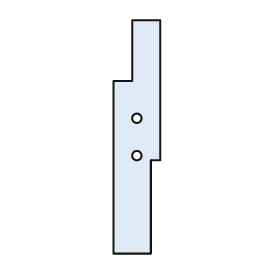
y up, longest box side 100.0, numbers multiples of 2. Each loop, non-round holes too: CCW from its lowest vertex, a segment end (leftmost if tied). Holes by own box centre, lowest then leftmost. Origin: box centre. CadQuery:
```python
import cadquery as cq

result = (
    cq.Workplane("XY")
    .moveTo(-10.0, -50.0)
    .lineTo(6.0, -50.0)
    .lineTo(6.0, -10.0)
    .lineTo(10.0, -10.0)
    .lineTo(10.0, 50.0)
    .lineTo(-2.0, 50.0)
    .lineTo(-2.0, 24.0)
    .lineTo(-10.0, 24.0)
    .close()
    .moveTo(0.0, -8.0)
    .circle(2.0)
    .moveTo(0.0, 8.0)
    .circle(2.0)
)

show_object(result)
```